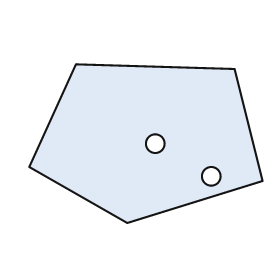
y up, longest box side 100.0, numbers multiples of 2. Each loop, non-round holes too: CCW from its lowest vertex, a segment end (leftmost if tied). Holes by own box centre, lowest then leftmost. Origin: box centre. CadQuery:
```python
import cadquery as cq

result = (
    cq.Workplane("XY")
    .moveTo(-8.0, -34.0)
    .lineTo(50.0, -16.0)
    .lineTo(38.0, 32.0)
    .lineTo(-30.0, 34.0)
    .lineTo(-50.0, -10.0)
    .close()
    .moveTo(28.0, -14.0)
    .circle(4.0)
    .moveTo(4.0, 0.0)
    .circle(4.0)
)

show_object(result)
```